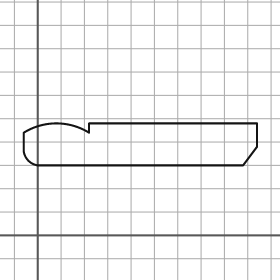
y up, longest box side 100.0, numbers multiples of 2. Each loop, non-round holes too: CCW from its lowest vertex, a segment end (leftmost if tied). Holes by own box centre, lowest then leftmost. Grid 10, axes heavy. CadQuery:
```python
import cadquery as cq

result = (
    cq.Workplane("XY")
    .moveTo(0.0, 30.0)
    .lineTo(88.0, 30.0)
    .lineTo(94.0, 38.0)
    .lineTo(94.0, 48.0)
    .lineTo(22.0, 48.0)
    .lineTo(22.0, 44.0)
    .threePointArc((8.0, 48.0), (-6.0, 44.0))
    .lineTo(-6.0, 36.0)
    .threePointArc((-4.0, 32.0), (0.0, 30.0))
    .close()
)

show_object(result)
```